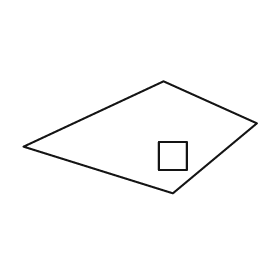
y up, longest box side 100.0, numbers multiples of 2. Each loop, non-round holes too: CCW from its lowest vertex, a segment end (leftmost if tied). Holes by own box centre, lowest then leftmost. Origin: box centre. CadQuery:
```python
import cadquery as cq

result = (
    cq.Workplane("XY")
    .moveTo(14.0, -24.0)
    .lineTo(50.0, 6.0)
    .lineTo(10.0, 24.0)
    .lineTo(-50.0, -4.0)
    .close()
    .moveTo(8.0, -14.0)
    .lineTo(20.0, -14.0)
    .lineTo(20.0, -2.0)
    .lineTo(8.0, -2.0)
    .close()
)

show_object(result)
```